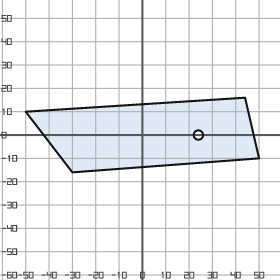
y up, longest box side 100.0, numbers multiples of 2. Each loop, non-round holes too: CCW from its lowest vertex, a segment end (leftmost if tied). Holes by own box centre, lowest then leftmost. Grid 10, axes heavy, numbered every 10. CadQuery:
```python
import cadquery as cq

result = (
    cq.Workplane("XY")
    .moveTo(-30.0, -16.0)
    .lineTo(50.0, -10.0)
    .lineTo(44.0, 16.0)
    .lineTo(-50.0, 10.0)
    .close()
    .moveTo(24.0, 0.0)
    .circle(2.0)
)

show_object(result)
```